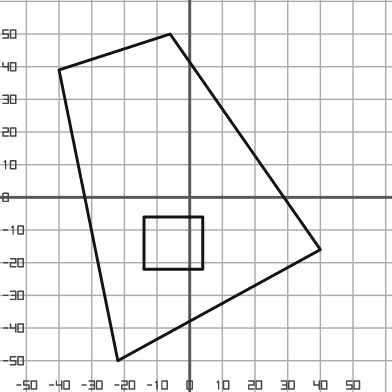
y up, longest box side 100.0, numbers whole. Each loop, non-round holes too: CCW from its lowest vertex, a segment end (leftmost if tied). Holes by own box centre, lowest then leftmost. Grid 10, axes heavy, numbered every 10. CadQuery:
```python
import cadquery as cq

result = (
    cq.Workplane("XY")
    .moveTo(-22.0, -50.0)
    .lineTo(40.0, -16.0)
    .lineTo(-6.0, 50.0)
    .lineTo(-40.0, 39.0)
    .close()
    .moveTo(-14.0, -22.0)
    .lineTo(4.0, -22.0)
    .lineTo(4.0, -6.0)
    .lineTo(-14.0, -6.0)
    .close()
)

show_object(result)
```